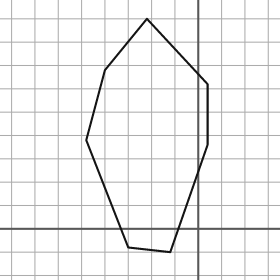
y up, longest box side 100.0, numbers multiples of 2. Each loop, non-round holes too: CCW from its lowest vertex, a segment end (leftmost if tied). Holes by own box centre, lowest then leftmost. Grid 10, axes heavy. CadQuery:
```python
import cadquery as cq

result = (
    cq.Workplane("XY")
    .moveTo(-12.0, -10.0)
    .lineTo(4.0, 36.0)
    .lineTo(4.0, 62.0)
    .lineTo(-22.0, 90.0)
    .lineTo(-40.0, 68.0)
    .lineTo(-48.0, 38.0)
    .lineTo(-30.0, -8.0)
    .close()
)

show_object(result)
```